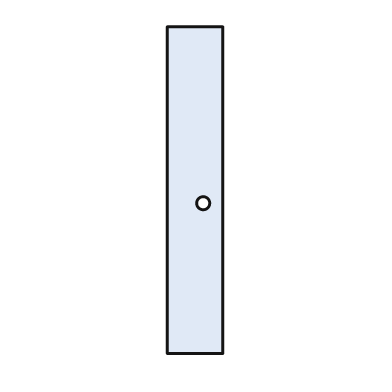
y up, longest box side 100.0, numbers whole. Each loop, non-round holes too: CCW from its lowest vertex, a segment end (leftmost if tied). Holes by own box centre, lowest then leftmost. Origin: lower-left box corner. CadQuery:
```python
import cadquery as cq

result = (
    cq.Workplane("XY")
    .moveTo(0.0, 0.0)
    .lineTo(17.0, 0.0)
    .lineTo(17.0, 100.0)
    .lineTo(0.0, 100.0)
    .close()
    .moveTo(11.0, 46.0)
    .circle(2.0)
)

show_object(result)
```